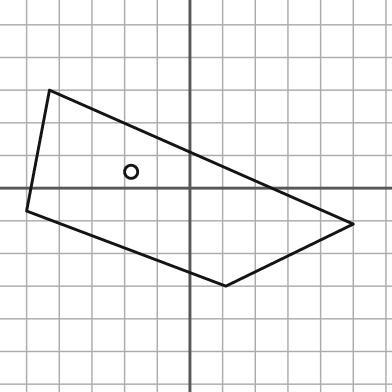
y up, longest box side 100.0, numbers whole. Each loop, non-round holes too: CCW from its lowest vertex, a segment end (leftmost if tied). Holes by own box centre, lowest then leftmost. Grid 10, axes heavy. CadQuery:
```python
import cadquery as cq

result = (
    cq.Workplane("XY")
    .moveTo(11.0, -30.0)
    .lineTo(50.0, -11.0)
    .lineTo(-43.0, 30.0)
    .lineTo(-50.0, -7.0)
    .close()
    .moveTo(-18.0, 5.0)
    .circle(2.0)
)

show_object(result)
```